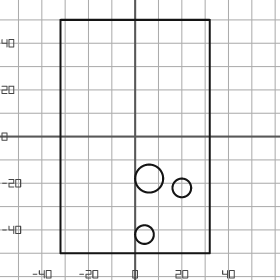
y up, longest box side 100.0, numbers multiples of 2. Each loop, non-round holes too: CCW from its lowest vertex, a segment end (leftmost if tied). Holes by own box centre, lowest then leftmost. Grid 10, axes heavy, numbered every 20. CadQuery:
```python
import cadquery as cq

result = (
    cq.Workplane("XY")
    .moveTo(-32.0, -50.0)
    .lineTo(32.0, -50.0)
    .lineTo(32.0, 50.0)
    .lineTo(-32.0, 50.0)
    .close()
    .moveTo(4.0, -42.0)
    .circle(4.0)
    .moveTo(20.0, -22.0)
    .circle(4.0)
    .moveTo(6.0, -18.0)
    .circle(6.0)
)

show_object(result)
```